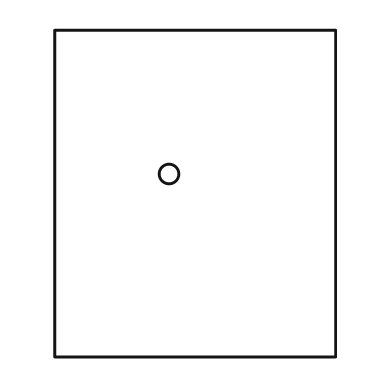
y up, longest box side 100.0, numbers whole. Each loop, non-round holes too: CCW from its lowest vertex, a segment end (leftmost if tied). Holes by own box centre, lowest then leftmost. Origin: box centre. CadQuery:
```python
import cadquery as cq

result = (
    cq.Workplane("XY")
    .moveTo(-43.0, -50.0)
    .lineTo(43.0, -50.0)
    .lineTo(43.0, 50.0)
    .lineTo(-43.0, 50.0)
    .close()
    .moveTo(-8.0, 6.0)
    .circle(3.0)
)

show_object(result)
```